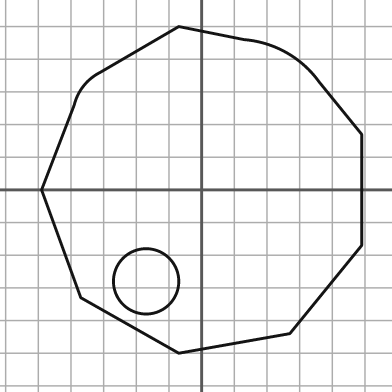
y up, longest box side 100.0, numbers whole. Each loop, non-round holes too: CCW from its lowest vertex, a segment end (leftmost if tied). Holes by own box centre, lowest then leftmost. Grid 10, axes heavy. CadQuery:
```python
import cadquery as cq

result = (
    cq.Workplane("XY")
    .moveTo(-7.0, -50.0)
    .lineTo(27.0, -44.0)
    .lineTo(49.0, -17.0)
    .lineTo(49.0, 17.0)
    .lineTo(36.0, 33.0)
    .threePointArc((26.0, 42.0), (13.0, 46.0))
    .lineTo(-7.0, 50.0)
    .lineTo(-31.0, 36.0)
    .threePointArc((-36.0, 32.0), (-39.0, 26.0))
    .lineTo(-49.0, 0.0)
    .lineTo(-37.0, -33.0)
    .close()
    .moveTo(-17.0, -28.0)
    .circle(10.0)
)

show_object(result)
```